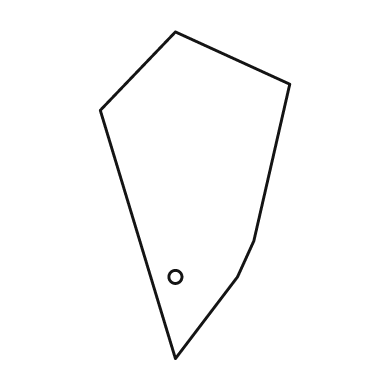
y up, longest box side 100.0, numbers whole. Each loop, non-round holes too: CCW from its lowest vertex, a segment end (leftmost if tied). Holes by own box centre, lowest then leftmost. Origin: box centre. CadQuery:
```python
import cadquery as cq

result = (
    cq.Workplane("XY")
    .moveTo(-6.0, -50.0)
    .lineTo(13.0, -25.0)
    .lineTo(18.0, -14.0)
    .lineTo(29.0, 34.0)
    .lineTo(-6.0, 50.0)
    .lineTo(-29.0, 26.0)
    .close()
    .moveTo(-6.0, -25.0)
    .circle(2.0)
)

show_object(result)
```